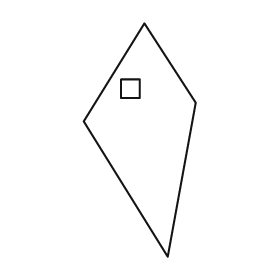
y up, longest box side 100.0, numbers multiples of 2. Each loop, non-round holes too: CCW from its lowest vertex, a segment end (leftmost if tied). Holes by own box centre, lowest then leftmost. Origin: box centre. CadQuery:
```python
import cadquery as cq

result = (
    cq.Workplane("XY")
    .moveTo(12.0, -50.0)
    .lineTo(24.0, 16.0)
    .lineTo(2.0, 50.0)
    .lineTo(-24.0, 8.0)
    .close()
    .moveTo(-8.0, 18.0)
    .lineTo(0.0, 18.0)
    .lineTo(0.0, 26.0)
    .lineTo(-8.0, 26.0)
    .close()
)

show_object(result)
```